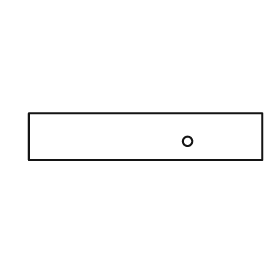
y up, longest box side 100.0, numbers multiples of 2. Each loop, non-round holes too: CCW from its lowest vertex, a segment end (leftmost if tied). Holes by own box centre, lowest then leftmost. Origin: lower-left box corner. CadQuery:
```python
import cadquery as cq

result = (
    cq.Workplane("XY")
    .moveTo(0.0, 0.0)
    .lineTo(100.0, 0.0)
    .lineTo(100.0, 20.0)
    .lineTo(0.0, 20.0)
    .close()
    .moveTo(68.0, 8.0)
    .circle(2.0)
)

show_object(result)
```